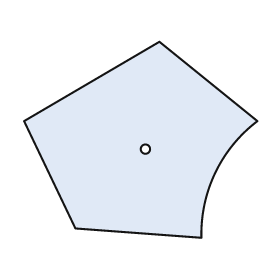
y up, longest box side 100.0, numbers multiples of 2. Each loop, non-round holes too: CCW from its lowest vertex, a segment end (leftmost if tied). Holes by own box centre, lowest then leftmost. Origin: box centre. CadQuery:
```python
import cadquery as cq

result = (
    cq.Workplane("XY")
    .moveTo(26.0, -42.0)
    .threePointArc((32.0, -14.0), (50.0, 8.0))
    .lineTo(8.0, 42.0)
    .lineTo(-50.0, 8.0)
    .lineTo(-28.0, -38.0)
    .close()
    .moveTo(2.0, -4.0)
    .circle(2.0)
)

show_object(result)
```